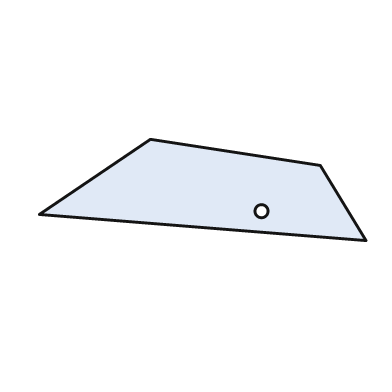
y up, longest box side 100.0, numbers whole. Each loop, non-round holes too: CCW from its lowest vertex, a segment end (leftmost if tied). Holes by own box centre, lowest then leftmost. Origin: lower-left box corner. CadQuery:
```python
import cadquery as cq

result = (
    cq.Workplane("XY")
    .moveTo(100.0, 0.0)
    .lineTo(86.0, 23.0)
    .lineTo(34.0, 31.0)
    .lineTo(0.0, 8.0)
    .close()
    .moveTo(68.0, 9.0)
    .circle(2.0)
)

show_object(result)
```